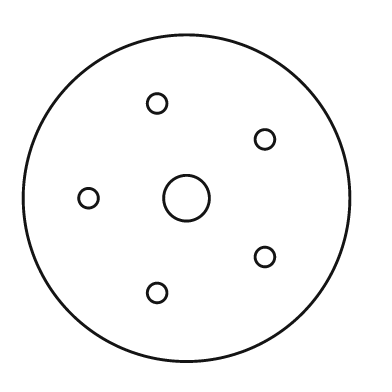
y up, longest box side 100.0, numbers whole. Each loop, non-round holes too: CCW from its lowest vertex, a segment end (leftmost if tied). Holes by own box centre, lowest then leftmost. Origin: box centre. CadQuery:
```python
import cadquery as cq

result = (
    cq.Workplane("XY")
    .moveTo(0.0, 0.0)
    .circle(50.0)
    .moveTo(-9.0, -29.0)
    .circle(3.0)
    .moveTo(24.0, -18.0)
    .circle(3.0)
    .moveTo(-30.0, 0.0)
    .circle(3.0)
    .moveTo(0.0, 0.0)
    .circle(7.0)
    .moveTo(24.0, 18.0)
    .circle(3.0)
    .moveTo(-9.0, 29.0)
    .circle(3.0)
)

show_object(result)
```